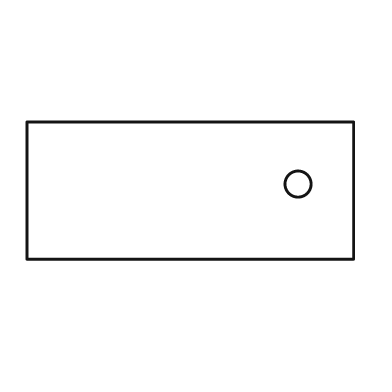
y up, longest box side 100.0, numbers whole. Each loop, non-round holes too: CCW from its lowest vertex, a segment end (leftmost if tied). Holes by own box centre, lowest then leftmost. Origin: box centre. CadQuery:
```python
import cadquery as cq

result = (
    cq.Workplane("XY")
    .moveTo(-50.0, -21.0)
    .lineTo(50.0, -21.0)
    .lineTo(50.0, 21.0)
    .lineTo(-50.0, 21.0)
    .close()
    .moveTo(33.0, 2.0)
    .circle(4.0)
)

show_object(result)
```